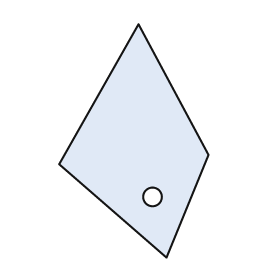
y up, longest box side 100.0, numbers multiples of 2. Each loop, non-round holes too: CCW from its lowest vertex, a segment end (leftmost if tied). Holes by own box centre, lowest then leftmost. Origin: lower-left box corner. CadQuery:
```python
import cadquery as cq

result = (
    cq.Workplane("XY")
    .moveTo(46.0, 0.0)
    .lineTo(64.0, 44.0)
    .lineTo(34.0, 100.0)
    .lineTo(0.0, 40.0)
    .close()
    .moveTo(40.0, 26.0)
    .circle(4.0)
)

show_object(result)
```